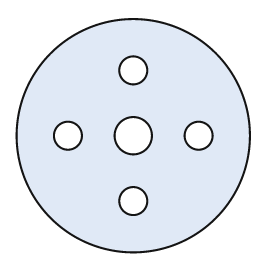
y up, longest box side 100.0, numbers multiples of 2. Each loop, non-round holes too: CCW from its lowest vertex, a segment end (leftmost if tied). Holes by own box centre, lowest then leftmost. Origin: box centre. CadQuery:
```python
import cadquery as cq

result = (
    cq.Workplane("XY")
    .moveTo(0.0, 0.0)
    .circle(50.0)
    .moveTo(0.0, -28.0)
    .circle(6.0)
    .moveTo(-28.0, 0.0)
    .circle(6.0)
    .moveTo(0.0, 0.0)
    .circle(8.0)
    .moveTo(28.0, 0.0)
    .circle(6.0)
    .moveTo(0.0, 28.0)
    .circle(6.0)
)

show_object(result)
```